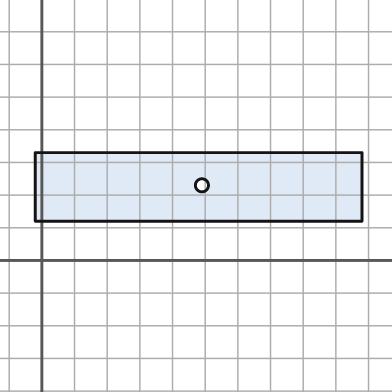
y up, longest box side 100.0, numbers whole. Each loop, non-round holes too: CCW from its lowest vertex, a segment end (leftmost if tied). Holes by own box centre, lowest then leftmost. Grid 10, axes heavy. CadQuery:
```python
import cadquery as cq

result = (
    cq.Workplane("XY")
    .moveTo(-2.0, 12.0)
    .lineTo(98.0, 12.0)
    .lineTo(98.0, 33.0)
    .lineTo(-2.0, 33.0)
    .close()
    .moveTo(49.0, 23.0)
    .circle(2.0)
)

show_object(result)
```